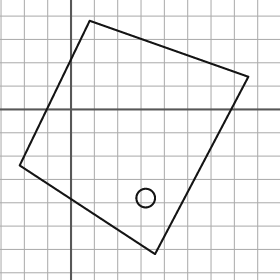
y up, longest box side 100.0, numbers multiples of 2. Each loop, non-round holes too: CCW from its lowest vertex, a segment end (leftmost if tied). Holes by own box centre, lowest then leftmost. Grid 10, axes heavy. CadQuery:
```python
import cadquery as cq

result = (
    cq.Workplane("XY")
    .moveTo(36.0, -62.0)
    .lineTo(76.0, 14.0)
    .lineTo(8.0, 38.0)
    .lineTo(-22.0, -24.0)
    .close()
    .moveTo(32.0, -38.0)
    .circle(4.0)
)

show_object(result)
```